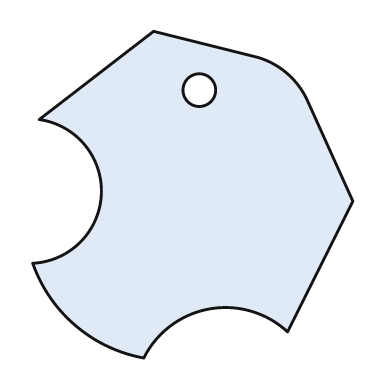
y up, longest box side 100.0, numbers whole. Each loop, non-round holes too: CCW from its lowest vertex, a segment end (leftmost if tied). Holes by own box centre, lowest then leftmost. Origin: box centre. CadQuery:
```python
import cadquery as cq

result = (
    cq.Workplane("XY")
    .moveTo(-15.0, -50.0)
    .threePointArc((5.0, -35.0), (29.0, -42.0))
    .lineTo(49.0, -2.0)
    .lineTo(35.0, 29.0)
    .threePointArc((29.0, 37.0), (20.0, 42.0))
    .lineTo(-12.0, 50.0)
    .lineTo(-47.0, 23.0)
    .threePointArc((-28.0, 0.0), (-49.0, -21.0))
    .threePointArc((-36.0, -40.0), (-15.0, -50.0))
    .close()
    .moveTo(2.0, 32.0)
    .circle(5.0)
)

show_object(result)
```